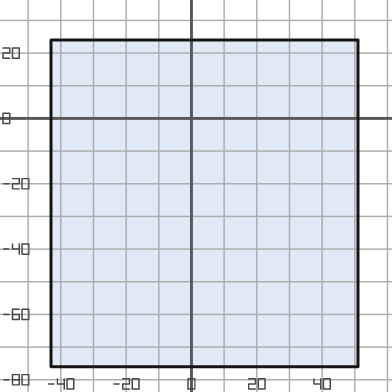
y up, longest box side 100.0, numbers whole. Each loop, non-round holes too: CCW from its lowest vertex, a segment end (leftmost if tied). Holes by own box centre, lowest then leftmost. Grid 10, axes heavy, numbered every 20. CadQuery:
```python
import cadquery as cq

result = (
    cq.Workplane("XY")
    .moveTo(-43.0, -76.0)
    .lineTo(51.0, -76.0)
    .lineTo(51.0, 24.0)
    .lineTo(-43.0, 24.0)
    .close()
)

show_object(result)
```